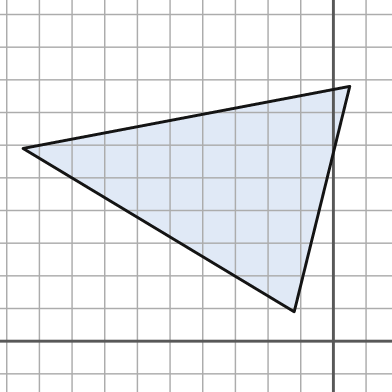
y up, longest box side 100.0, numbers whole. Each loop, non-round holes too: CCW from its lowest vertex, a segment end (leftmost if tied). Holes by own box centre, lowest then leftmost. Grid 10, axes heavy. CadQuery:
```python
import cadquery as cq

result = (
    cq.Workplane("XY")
    .moveTo(-12.0, 9.0)
    .lineTo(5.0, 78.0)
    .lineTo(-95.0, 59.0)
    .close()
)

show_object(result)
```